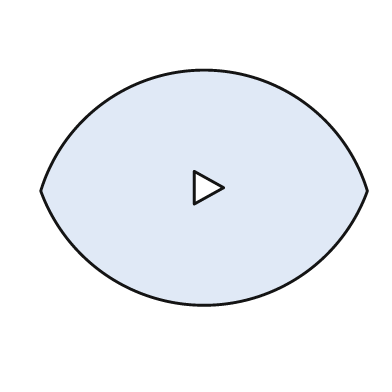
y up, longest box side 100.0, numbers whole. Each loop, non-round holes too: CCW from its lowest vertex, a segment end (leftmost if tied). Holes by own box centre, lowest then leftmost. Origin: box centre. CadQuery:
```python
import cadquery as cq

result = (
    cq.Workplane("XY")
    .moveTo(-50.0, -1.0)
    .threePointArc((0.0, -36.0), (50.0, -1.0))
    .threePointArc((0.0, 36.0), (-50.0, -1.0))
    .close()
    .moveTo(-3.0, -5.0)
    .lineTo(6.0, 0.0)
    .lineTo(-3.0, 5.0)
    .close()
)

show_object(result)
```